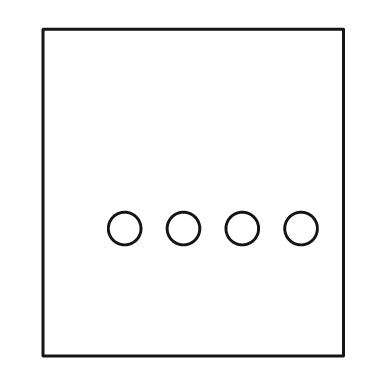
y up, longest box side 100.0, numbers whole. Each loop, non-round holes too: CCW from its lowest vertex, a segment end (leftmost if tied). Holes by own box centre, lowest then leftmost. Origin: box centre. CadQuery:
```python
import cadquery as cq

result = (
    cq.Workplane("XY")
    .moveTo(-46.0, -50.0)
    .lineTo(46.0, -50.0)
    .lineTo(46.0, 50.0)
    .lineTo(-46.0, 50.0)
    .close()
    .moveTo(-21.0, -11.0)
    .circle(5.0)
    .moveTo(-3.0, -11.0)
    .circle(5.0)
    .moveTo(15.0, -11.0)
    .circle(5.0)
    .moveTo(33.0, -11.0)
    .circle(5.0)
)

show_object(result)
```